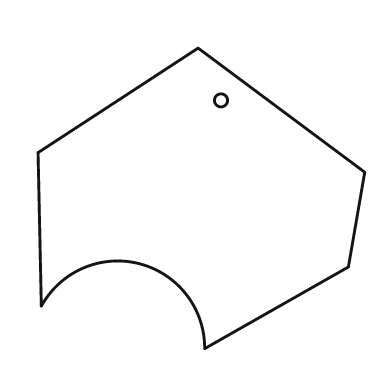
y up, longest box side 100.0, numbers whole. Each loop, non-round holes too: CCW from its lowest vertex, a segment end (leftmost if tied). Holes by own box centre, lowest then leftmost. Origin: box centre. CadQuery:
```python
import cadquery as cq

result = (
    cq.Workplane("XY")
    .moveTo(1.0, -46.0)
    .lineTo(45.0, -21.0)
    .lineTo(50.0, 8.0)
    .lineTo(-1.0, 46.0)
    .lineTo(-50.0, 14.0)
    .lineTo(-49.0, -33.0)
    .threePointArc((-19.0, -20.0), (1.0, -46.0))
    .close()
    .moveTo(6.0, 30.0)
    .circle(2.0)
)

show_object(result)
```